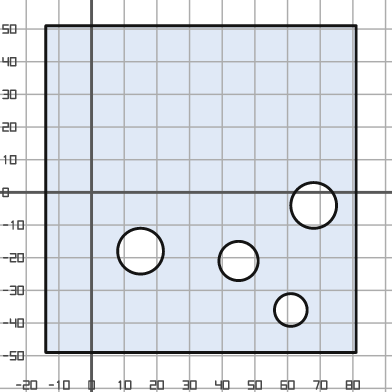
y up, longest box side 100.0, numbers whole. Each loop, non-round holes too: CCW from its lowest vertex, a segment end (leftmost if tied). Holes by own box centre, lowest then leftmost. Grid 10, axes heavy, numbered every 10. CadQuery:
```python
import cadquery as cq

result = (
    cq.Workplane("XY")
    .moveTo(-14.0, -49.0)
    .lineTo(81.0, -49.0)
    .lineTo(81.0, 51.0)
    .lineTo(-14.0, 51.0)
    .close()
    .moveTo(61.0, -36.0)
    .circle(5.0)
    .moveTo(45.0, -21.0)
    .circle(6.0)
    .moveTo(15.0, -18.0)
    .circle(7.0)
    .moveTo(68.0, -4.0)
    .circle(7.0)
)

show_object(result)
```